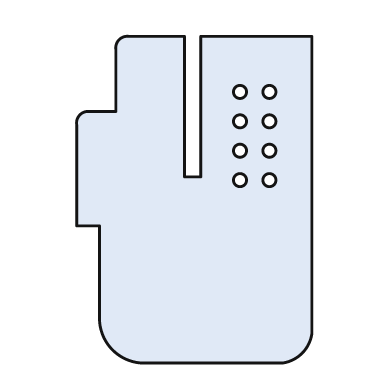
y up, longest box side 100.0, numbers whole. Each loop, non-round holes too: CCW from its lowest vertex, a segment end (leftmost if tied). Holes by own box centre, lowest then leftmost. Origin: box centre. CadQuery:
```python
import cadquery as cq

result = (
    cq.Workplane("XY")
    .moveTo(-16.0, -50.0)
    .lineTo(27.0, -50.0)
    .threePointArc((33.0, -47.0), (36.0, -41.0))
    .lineTo(36.0, 50.0)
    .lineTo(2.0, 50.0)
    .lineTo(2.0, 7.0)
    .lineTo(-3.0, 7.0)
    .lineTo(-3.0, 50.0)
    .lineTo(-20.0, 50.0)
    .threePointArc((-23.0, 49.0), (-24.0, 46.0))
    .lineTo(-24.0, 27.0)
    .lineTo(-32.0, 27.0)
    .threePointArc((-35.0, 26.0), (-36.0, 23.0))
    .lineTo(-36.0, -8.0)
    .lineTo(-29.0, -8.0)
    .lineTo(-29.0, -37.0)
    .threePointArc((-25.0, -46.0), (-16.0, -50.0))
    .close()
    .moveTo(14.0, 6.0)
    .circle(2.0)
    .moveTo(23.0, 6.0)
    .circle(2.0)
    .moveTo(14.0, 15.0)
    .circle(2.0)
    .moveTo(23.0, 15.0)
    .circle(2.0)
    .moveTo(14.0, 24.0)
    .circle(2.0)
    .moveTo(23.0, 24.0)
    .circle(2.0)
    .moveTo(14.0, 33.0)
    .circle(2.0)
    .moveTo(23.0, 33.0)
    .circle(2.0)
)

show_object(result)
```